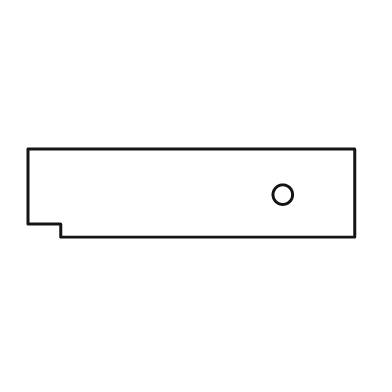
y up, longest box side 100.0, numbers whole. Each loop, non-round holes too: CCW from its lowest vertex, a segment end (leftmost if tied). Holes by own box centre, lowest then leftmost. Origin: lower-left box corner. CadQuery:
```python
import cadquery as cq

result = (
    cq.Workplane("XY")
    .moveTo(10.0, 0.0)
    .lineTo(100.0, 0.0)
    .lineTo(100.0, 27.0)
    .lineTo(0.0, 27.0)
    .lineTo(0.0, 4.0)
    .lineTo(10.0, 4.0)
    .close()
    .moveTo(78.0, 13.0)
    .circle(3.0)
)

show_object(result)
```